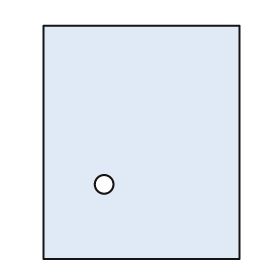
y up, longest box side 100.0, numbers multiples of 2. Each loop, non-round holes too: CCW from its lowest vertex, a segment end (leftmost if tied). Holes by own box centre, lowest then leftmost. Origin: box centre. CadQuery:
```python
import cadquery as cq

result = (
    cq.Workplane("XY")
    .moveTo(-42.0, -50.0)
    .lineTo(42.0, -50.0)
    .lineTo(42.0, 50.0)
    .lineTo(-42.0, 50.0)
    .close()
    .moveTo(-16.0, -18.0)
    .circle(4.0)
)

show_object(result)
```